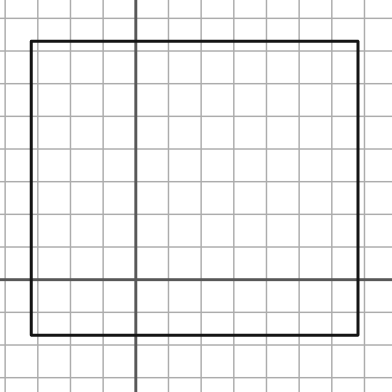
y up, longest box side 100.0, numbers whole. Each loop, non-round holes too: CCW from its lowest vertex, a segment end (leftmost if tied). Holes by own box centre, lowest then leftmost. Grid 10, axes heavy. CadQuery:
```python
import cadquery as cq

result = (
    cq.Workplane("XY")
    .moveTo(-32.0, -17.0)
    .lineTo(68.0, -17.0)
    .lineTo(68.0, 73.0)
    .lineTo(-32.0, 73.0)
    .close()
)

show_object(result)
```